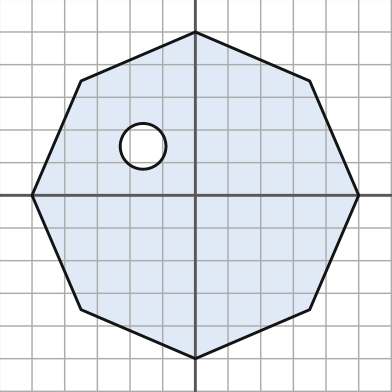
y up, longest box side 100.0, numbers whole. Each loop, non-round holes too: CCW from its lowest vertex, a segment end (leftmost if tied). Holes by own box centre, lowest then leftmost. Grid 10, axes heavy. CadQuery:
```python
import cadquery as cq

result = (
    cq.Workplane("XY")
    .moveTo(0.0, -50.0)
    .lineTo(35.0, -35.0)
    .lineTo(50.0, 0.0)
    .lineTo(35.0, 35.0)
    .lineTo(0.0, 50.0)
    .lineTo(-35.0, 35.0)
    .lineTo(-50.0, 0.0)
    .lineTo(-35.0, -35.0)
    .close()
    .moveTo(-16.0, 15.0)
    .circle(7.0)
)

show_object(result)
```